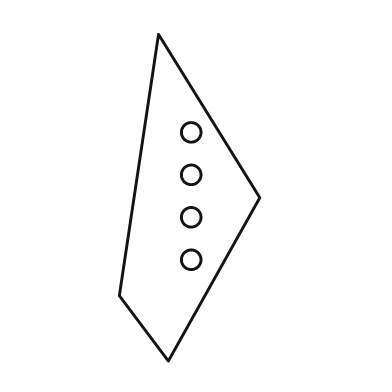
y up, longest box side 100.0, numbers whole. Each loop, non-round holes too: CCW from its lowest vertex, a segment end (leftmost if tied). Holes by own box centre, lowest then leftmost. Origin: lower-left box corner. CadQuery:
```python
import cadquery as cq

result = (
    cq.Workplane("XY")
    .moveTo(15.0, 0.0)
    .lineTo(43.0, 50.0)
    .lineTo(12.0, 100.0)
    .lineTo(0.0, 20.0)
    .close()
    .moveTo(22.0, 31.0)
    .circle(3.0)
    .moveTo(22.0, 44.0)
    .circle(3.0)
    .moveTo(22.0, 57.0)
    .circle(3.0)
    .moveTo(22.0, 70.0)
    .circle(3.0)
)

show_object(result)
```